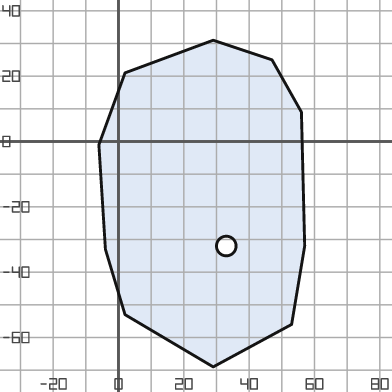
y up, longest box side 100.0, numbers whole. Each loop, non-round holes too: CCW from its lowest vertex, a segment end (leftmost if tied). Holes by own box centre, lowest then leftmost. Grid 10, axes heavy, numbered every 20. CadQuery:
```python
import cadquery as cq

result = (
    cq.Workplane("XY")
    .moveTo(29.0, -69.0)
    .lineTo(53.0, -56.0)
    .lineTo(57.0, -32.0)
    .lineTo(56.0, 9.0)
    .lineTo(47.0, 25.0)
    .lineTo(29.0, 31.0)
    .lineTo(2.0, 21.0)
    .lineTo(-6.0, -1.0)
    .lineTo(-4.0, -33.0)
    .lineTo(2.0, -53.0)
    .close()
    .moveTo(33.0, -32.0)
    .circle(3.0)
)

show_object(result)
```